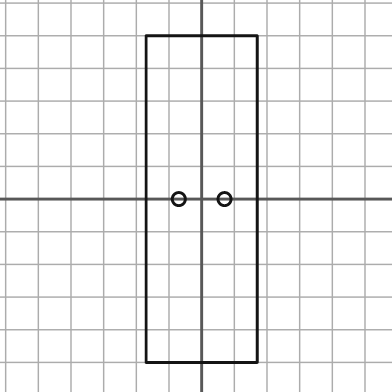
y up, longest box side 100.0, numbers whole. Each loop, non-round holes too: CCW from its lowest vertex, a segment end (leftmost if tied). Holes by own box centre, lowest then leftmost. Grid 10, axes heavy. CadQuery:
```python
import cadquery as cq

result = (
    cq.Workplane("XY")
    .moveTo(-17.0, -50.0)
    .lineTo(17.0, -50.0)
    .lineTo(17.0, 50.0)
    .lineTo(-17.0, 50.0)
    .close()
    .moveTo(-7.0, 0.0)
    .circle(2.0)
    .moveTo(7.0, 0.0)
    .circle(2.0)
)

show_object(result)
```